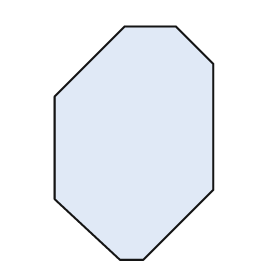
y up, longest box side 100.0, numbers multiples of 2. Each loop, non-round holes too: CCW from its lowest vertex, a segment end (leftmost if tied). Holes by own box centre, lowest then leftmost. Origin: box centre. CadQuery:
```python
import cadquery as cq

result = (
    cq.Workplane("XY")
    .moveTo(-6.0, -50.0)
    .lineTo(4.0, -50.0)
    .lineTo(34.0, -20.0)
    .lineTo(34.0, 34.0)
    .lineTo(18.0, 50.0)
    .lineTo(-4.0, 50.0)
    .lineTo(-34.0, 20.0)
    .lineTo(-34.0, -24.0)
    .close()
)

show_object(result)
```